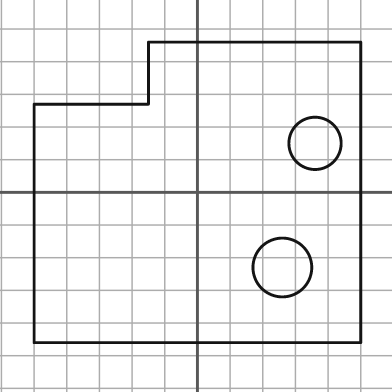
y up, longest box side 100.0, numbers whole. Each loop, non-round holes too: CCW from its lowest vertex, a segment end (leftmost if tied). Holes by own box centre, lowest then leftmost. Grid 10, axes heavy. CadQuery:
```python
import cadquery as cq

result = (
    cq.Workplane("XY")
    .moveTo(-50.0, -46.0)
    .lineTo(50.0, -46.0)
    .lineTo(50.0, 46.0)
    .lineTo(-15.0, 46.0)
    .lineTo(-15.0, 27.0)
    .lineTo(-50.0, 27.0)
    .close()
    .moveTo(26.0, -23.0)
    .circle(9.0)
    .moveTo(36.0, 15.0)
    .circle(8.0)
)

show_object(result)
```